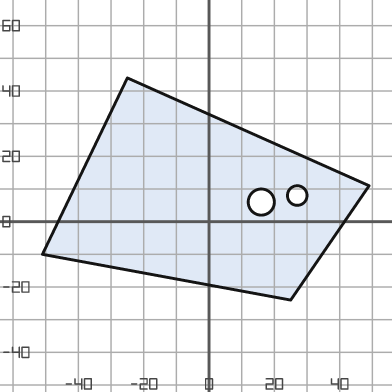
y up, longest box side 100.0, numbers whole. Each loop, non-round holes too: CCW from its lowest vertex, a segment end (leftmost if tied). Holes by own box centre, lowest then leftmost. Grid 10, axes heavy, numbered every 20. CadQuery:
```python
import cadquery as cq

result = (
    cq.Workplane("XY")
    .moveTo(25.0, -24.0)
    .lineTo(49.0, 11.0)
    .lineTo(-25.0, 44.0)
    .lineTo(-51.0, -10.0)
    .close()
    .moveTo(16.0, 6.0)
    .circle(4.0)
    .moveTo(27.0, 8.0)
    .circle(3.0)
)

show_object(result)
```